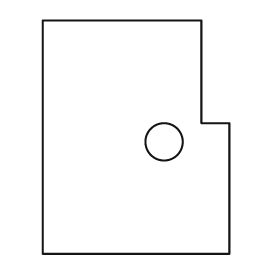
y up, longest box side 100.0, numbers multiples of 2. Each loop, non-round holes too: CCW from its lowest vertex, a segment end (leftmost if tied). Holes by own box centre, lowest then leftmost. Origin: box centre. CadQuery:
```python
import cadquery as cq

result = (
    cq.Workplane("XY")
    .moveTo(-40.0, -50.0)
    .lineTo(40.0, -50.0)
    .lineTo(40.0, 6.0)
    .lineTo(28.0, 6.0)
    .lineTo(28.0, 50.0)
    .lineTo(-40.0, 50.0)
    .close()
    .moveTo(12.0, -2.0)
    .circle(8.0)
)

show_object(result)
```